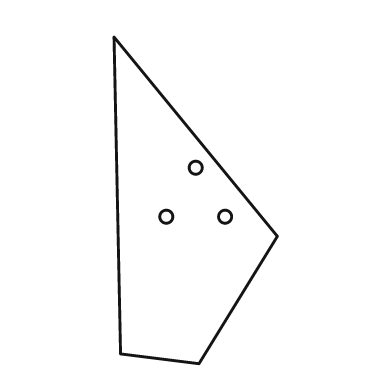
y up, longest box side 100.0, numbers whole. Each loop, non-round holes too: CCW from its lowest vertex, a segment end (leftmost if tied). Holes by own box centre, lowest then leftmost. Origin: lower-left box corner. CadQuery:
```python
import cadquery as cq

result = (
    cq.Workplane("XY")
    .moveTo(26.0, 0.0)
    .lineTo(50.0, 39.0)
    .lineTo(0.0, 100.0)
    .lineTo(2.0, 3.0)
    .close()
    .moveTo(16.0, 45.0)
    .circle(2.0)
    .moveTo(34.0, 45.0)
    .circle(2.0)
    .moveTo(25.0, 60.0)
    .circle(2.0)
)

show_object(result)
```